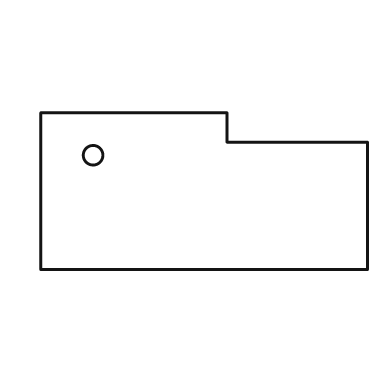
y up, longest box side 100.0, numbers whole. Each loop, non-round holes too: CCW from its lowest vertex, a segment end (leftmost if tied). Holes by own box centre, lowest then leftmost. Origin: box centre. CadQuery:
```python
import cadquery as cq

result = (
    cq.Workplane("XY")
    .moveTo(-50.0, -24.0)
    .lineTo(50.0, -24.0)
    .lineTo(50.0, 15.0)
    .lineTo(7.0, 15.0)
    .lineTo(7.0, 24.0)
    .lineTo(-50.0, 24.0)
    .close()
    .moveTo(-34.0, 11.0)
    .circle(3.0)
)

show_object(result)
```